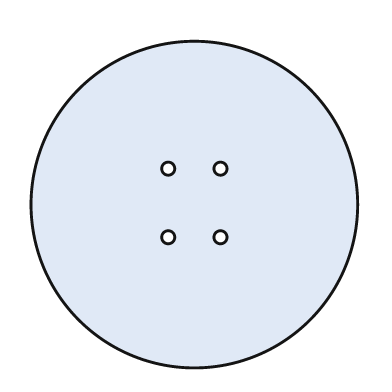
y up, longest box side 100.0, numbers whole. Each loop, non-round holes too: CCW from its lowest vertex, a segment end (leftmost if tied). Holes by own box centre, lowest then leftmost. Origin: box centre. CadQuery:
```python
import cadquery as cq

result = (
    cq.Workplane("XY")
    .moveTo(0.0, 0.0)
    .circle(50.0)
    .moveTo(-8.0, -10.0)
    .circle(2.0)
    .moveTo(8.0, -10.0)
    .circle(2.0)
    .moveTo(-8.0, 11.0)
    .circle(2.0)
    .moveTo(8.0, 11.0)
    .circle(2.0)
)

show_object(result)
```